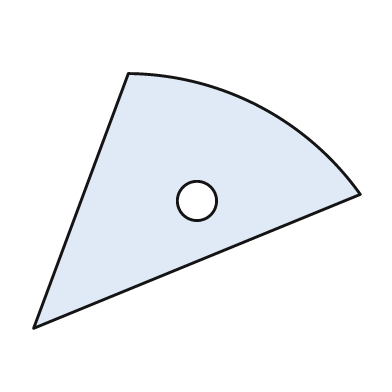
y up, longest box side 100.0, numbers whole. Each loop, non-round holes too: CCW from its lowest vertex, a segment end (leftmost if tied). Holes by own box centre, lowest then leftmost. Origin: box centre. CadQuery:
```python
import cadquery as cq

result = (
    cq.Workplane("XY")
    .moveTo(-50.0, -39.0)
    .lineTo(50.0, 2.0)
    .threePointArc((19.0, 29.0), (-21.0, 39.0))
    .close()
    .moveTo(0.0, 0.0)
    .circle(6.0)
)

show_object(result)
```